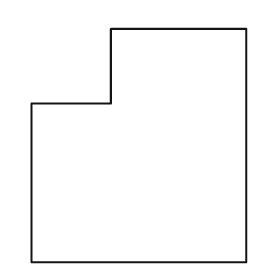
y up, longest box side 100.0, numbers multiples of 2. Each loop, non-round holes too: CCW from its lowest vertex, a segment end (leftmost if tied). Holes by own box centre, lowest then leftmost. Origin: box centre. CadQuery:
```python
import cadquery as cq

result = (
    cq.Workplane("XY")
    .moveTo(-46.0, -50.0)
    .lineTo(46.0, -50.0)
    .lineTo(46.0, 50.0)
    .lineTo(-12.0, 50.0)
    .lineTo(-12.0, 18.0)
    .lineTo(-46.0, 18.0)
    .close()
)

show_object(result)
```